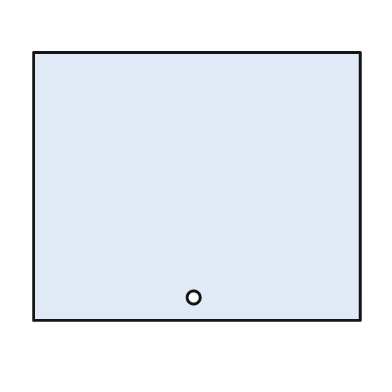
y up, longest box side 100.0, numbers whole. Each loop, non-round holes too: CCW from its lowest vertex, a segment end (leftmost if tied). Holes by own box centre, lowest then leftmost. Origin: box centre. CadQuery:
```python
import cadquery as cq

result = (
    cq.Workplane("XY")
    .moveTo(-50.0, -41.0)
    .lineTo(50.0, -41.0)
    .lineTo(50.0, 41.0)
    .lineTo(-50.0, 41.0)
    .close()
    .moveTo(-1.0, -34.0)
    .circle(2.0)
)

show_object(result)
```